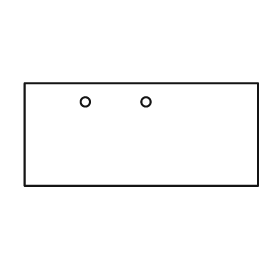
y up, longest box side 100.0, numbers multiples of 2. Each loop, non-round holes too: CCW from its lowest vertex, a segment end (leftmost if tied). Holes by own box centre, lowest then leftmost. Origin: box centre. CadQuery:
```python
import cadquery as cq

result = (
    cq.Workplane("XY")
    .moveTo(-50.0, -22.0)
    .lineTo(50.0, -22.0)
    .lineTo(50.0, 22.0)
    .lineTo(-50.0, 22.0)
    .close()
    .moveTo(-24.0, 14.0)
    .circle(2.0)
    .moveTo(2.0, 14.0)
    .circle(2.0)
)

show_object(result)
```